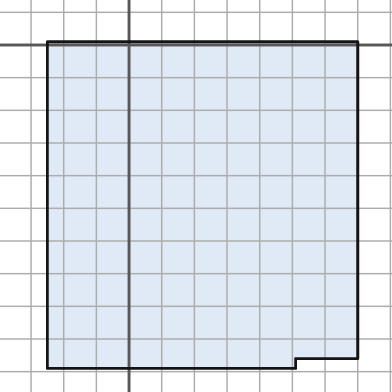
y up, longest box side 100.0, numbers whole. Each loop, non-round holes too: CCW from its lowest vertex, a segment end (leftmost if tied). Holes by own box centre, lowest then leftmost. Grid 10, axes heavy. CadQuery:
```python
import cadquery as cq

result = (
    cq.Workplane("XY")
    .moveTo(-25.0, -99.0)
    .lineTo(51.0, -99.0)
    .lineTo(51.0, -96.0)
    .lineTo(70.0, -96.0)
    .lineTo(70.0, 1.0)
    .lineTo(-25.0, 1.0)
    .close()
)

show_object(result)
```